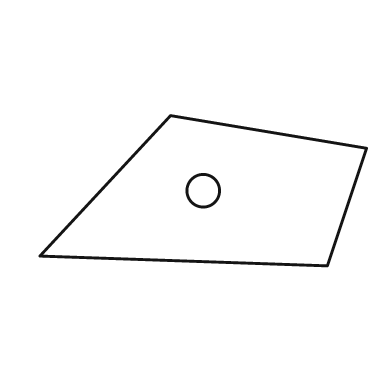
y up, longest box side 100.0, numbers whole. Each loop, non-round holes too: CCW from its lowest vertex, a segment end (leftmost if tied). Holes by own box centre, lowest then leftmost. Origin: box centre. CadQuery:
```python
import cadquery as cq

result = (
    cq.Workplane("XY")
    .moveTo(38.0, -23.0)
    .lineTo(50.0, 13.0)
    .lineTo(-10.0, 23.0)
    .lineTo(-50.0, -20.0)
    .close()
    .moveTo(0.0, 0.0)
    .circle(5.0)
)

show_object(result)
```